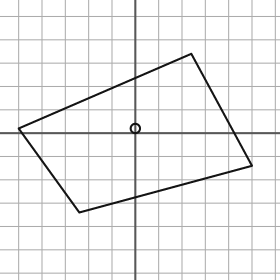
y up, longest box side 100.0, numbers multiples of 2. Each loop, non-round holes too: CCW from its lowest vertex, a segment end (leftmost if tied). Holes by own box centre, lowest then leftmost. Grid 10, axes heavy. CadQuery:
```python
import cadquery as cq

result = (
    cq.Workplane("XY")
    .moveTo(-24.0, -34.0)
    .lineTo(50.0, -14.0)
    .lineTo(24.0, 34.0)
    .lineTo(-50.0, 2.0)
    .close()
    .moveTo(0.0, 2.0)
    .circle(2.0)
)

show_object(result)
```